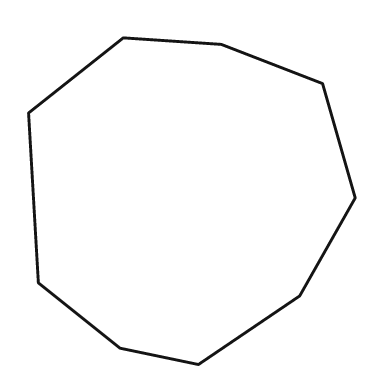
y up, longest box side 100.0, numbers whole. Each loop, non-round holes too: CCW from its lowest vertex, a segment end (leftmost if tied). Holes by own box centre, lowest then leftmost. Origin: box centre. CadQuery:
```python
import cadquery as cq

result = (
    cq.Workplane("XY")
    .moveTo(2.0, -50.0)
    .lineTo(33.0, -29.0)
    .lineTo(50.0, 1.0)
    .lineTo(40.0, 36.0)
    .lineTo(9.0, 48.0)
    .lineTo(-21.0, 50.0)
    .lineTo(-50.0, 27.0)
    .lineTo(-47.0, -25.0)
    .lineTo(-22.0, -45.0)
    .close()
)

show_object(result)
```